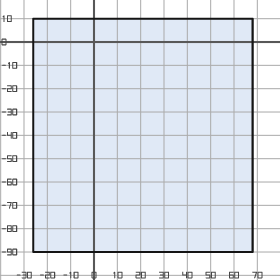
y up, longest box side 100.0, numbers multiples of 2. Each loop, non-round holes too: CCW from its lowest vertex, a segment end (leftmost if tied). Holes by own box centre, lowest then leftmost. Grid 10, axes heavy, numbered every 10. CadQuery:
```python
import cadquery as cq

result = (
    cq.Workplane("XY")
    .moveTo(-26.0, -90.0)
    .lineTo(68.0, -90.0)
    .lineTo(68.0, 10.0)
    .lineTo(-26.0, 10.0)
    .close()
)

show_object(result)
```